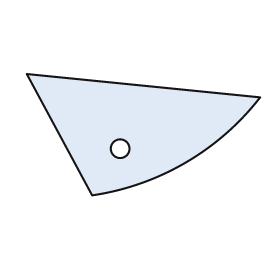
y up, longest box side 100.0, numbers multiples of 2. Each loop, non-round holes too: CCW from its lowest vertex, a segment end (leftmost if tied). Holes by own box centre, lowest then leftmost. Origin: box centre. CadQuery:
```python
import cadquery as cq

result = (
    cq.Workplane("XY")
    .moveTo(-22.0, -26.0)
    .threePointArc((18.0, -12.0), (50.0, 16.0))
    .lineTo(-50.0, 26.0)
    .close()
    .moveTo(-10.0, -6.0)
    .circle(4.0)
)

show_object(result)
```